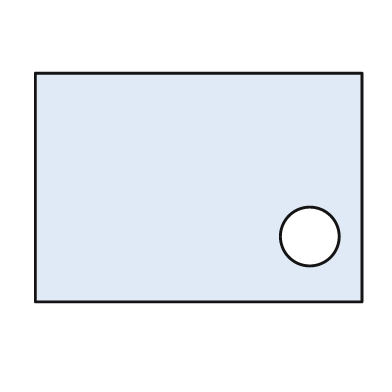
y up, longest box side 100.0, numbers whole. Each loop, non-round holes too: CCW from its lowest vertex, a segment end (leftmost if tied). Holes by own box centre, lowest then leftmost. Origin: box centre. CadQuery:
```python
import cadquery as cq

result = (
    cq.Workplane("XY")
    .moveTo(-50.0, -35.0)
    .lineTo(50.0, -35.0)
    .lineTo(50.0, 35.0)
    .lineTo(-50.0, 35.0)
    .close()
    .moveTo(34.0, -15.0)
    .circle(9.0)
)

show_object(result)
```